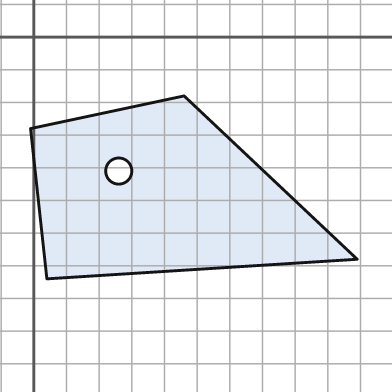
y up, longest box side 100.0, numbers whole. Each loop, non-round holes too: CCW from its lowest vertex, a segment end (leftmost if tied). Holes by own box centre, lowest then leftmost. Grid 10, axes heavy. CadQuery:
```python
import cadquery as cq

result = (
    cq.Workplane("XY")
    .moveTo(4.0, -74.0)
    .lineTo(99.0, -68.0)
    .lineTo(46.0, -18.0)
    .lineTo(-1.0, -28.0)
    .close()
    .moveTo(26.0, -41.0)
    .circle(4.0)
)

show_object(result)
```